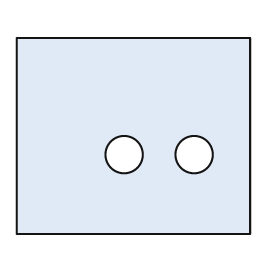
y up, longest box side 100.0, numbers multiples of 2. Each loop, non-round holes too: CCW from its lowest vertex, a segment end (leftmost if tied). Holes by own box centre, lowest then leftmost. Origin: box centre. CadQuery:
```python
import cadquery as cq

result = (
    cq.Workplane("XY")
    .moveTo(-50.0, -42.0)
    .lineTo(50.0, -42.0)
    .lineTo(50.0, 42.0)
    .lineTo(-50.0, 42.0)
    .close()
    .moveTo(-4.0, -8.0)
    .circle(8.0)
    .moveTo(26.0, -8.0)
    .circle(8.0)
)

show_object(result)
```